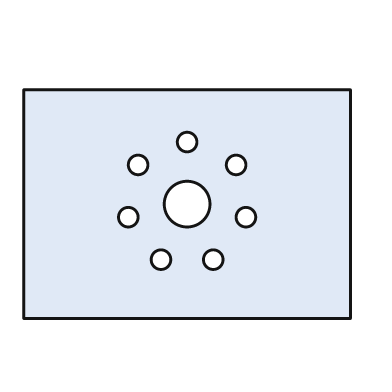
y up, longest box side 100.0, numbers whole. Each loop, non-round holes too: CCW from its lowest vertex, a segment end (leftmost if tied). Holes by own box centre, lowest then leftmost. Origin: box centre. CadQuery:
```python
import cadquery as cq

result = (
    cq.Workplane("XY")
    .moveTo(-50.0, -35.0)
    .lineTo(50.0, -35.0)
    .lineTo(50.0, 35.0)
    .lineTo(-50.0, 35.0)
    .close()
    .moveTo(-8.0, -17.0)
    .circle(3.0)
    .moveTo(8.0, -17.0)
    .circle(3.0)
    .moveTo(-18.0, -4.0)
    .circle(3.0)
    .moveTo(18.0, -4.0)
    .circle(3.0)
    .moveTo(0.0, 0.0)
    .circle(7.0)
    .moveTo(-15.0, 12.0)
    .circle(3.0)
    .moveTo(15.0, 12.0)
    .circle(3.0)
    .moveTo(0.0, 19.0)
    .circle(3.0)
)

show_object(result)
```